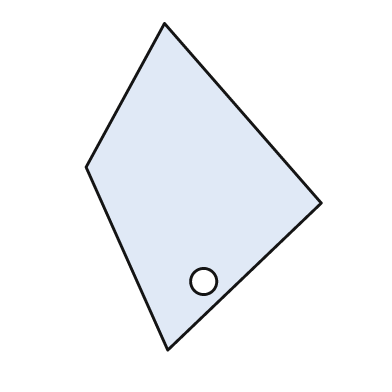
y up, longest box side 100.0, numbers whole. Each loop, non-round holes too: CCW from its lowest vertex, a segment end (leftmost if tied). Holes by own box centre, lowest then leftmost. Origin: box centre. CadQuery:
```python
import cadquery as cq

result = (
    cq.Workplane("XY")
    .moveTo(-11.0, -50.0)
    .lineTo(36.0, -5.0)
    .lineTo(-12.0, 50.0)
    .lineTo(-36.0, 6.0)
    .close()
    .moveTo(0.0, -29.0)
    .circle(4.0)
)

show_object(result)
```